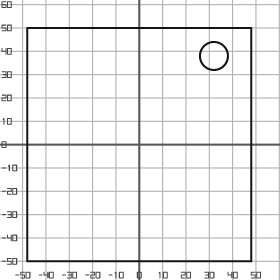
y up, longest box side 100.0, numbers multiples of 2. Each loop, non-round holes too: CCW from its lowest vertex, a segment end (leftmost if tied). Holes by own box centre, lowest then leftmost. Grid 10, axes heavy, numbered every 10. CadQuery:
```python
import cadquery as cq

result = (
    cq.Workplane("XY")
    .moveTo(-48.0, -50.0)
    .lineTo(48.0, -50.0)
    .lineTo(48.0, 50.0)
    .lineTo(-48.0, 50.0)
    .close()
    .moveTo(32.0, 38.0)
    .circle(6.0)
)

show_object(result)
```